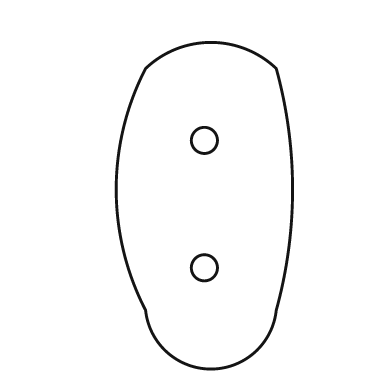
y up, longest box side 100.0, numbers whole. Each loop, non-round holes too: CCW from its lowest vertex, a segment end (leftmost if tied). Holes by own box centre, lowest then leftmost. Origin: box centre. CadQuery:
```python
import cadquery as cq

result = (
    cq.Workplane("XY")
    .moveTo(-18.0, -32.0)
    .threePointArc((2.0, -50.0), (22.0, -32.0))
    .threePointArc((27.0, 5.0), (22.0, 42.0))
    .threePointArc((2.0, 50.0), (-18.0, 42.0))
    .threePointArc((-27.0, 5.0), (-18.0, -32.0))
    .close()
    .moveTo(0.0, -19.0)
    .circle(4.0)
    .moveTo(0.0, 20.0)
    .circle(4.0)
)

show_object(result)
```